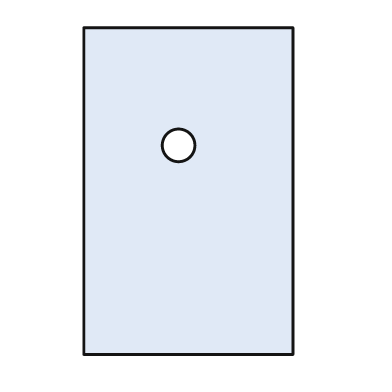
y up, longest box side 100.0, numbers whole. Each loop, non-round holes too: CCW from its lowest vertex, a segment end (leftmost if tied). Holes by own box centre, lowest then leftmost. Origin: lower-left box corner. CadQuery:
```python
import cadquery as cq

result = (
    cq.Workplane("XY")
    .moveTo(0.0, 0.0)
    .lineTo(64.0, 0.0)
    .lineTo(64.0, 100.0)
    .lineTo(0.0, 100.0)
    .close()
    .moveTo(29.0, 64.0)
    .circle(5.0)
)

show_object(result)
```